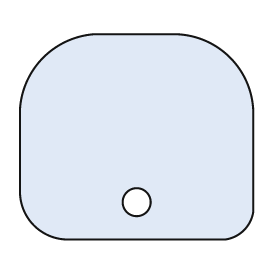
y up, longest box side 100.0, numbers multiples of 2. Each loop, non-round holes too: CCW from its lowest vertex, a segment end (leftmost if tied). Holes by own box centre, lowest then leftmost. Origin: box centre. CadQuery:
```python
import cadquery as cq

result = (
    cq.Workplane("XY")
    .moveTo(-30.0, -44.0)
    .lineTo(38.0, -44.0)
    .threePointArc((46.0, -40.0), (50.0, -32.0))
    .lineTo(50.0, 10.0)
    .threePointArc((40.0, 34.0), (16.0, 44.0))
    .lineTo(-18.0, 44.0)
    .threePointArc((-40.0, 34.0), (-50.0, 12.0))
    .lineTo(-50.0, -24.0)
    .threePointArc((-44.0, -38.0), (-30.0, -44.0))
    .close()
    .moveTo(0.0, -28.0)
    .circle(6.0)
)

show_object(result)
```